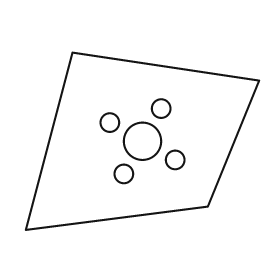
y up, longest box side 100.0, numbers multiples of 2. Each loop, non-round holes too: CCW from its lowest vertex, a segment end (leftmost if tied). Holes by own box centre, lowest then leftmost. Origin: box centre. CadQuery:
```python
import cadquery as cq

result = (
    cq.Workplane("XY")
    .moveTo(-50.0, -38.0)
    .lineTo(28.0, -28.0)
    .lineTo(50.0, 26.0)
    .lineTo(-30.0, 38.0)
    .close()
    .moveTo(-8.0, -14.0)
    .circle(4.0)
    .moveTo(14.0, -8.0)
    .circle(4.0)
    .moveTo(0.0, 0.0)
    .circle(8.0)
    .moveTo(-14.0, 8.0)
    .circle(4.0)
    .moveTo(8.0, 14.0)
    .circle(4.0)
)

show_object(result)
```